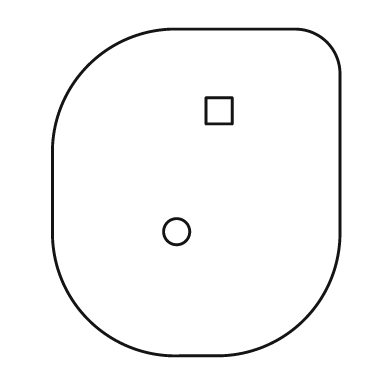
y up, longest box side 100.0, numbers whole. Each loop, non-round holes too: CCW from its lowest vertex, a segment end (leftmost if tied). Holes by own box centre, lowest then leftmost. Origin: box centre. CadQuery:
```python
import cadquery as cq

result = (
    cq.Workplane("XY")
    .moveTo(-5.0, -50.0)
    .lineTo(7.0, -50.0)
    .threePointArc((33.0, -39.0), (44.0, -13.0))
    .lineTo(44.0, 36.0)
    .threePointArc((40.0, 46.0), (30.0, 50.0))
    .lineTo(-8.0, 50.0)
    .threePointArc((-33.0, 39.0), (-44.0, 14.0))
    .lineTo(-44.0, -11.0)
    .threePointArc((-33.0, -39.0), (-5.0, -50.0))
    .close()
    .moveTo(-6.0, -12.0)
    .circle(4.0)
    .moveTo(3.0, 21.0)
    .lineTo(11.0, 21.0)
    .lineTo(11.0, 29.0)
    .lineTo(3.0, 29.0)
    .close()
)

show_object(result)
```